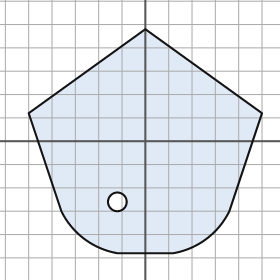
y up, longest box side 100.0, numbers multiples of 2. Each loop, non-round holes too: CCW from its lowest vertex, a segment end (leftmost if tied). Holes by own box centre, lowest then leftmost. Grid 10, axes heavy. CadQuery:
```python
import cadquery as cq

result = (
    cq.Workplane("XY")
    .moveTo(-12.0, -48.0)
    .lineTo(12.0, -48.0)
    .threePointArc((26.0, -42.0), (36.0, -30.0))
    .lineTo(50.0, 12.0)
    .lineTo(0.0, 48.0)
    .lineTo(-50.0, 12.0)
    .lineTo(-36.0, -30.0)
    .threePointArc((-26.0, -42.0), (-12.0, -48.0))
    .close()
    .moveTo(-12.0, -26.0)
    .circle(4.0)
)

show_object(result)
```